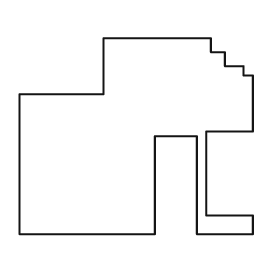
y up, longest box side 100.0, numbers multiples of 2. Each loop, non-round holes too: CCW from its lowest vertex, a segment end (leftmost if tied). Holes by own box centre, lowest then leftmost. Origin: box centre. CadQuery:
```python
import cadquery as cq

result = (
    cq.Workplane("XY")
    .moveTo(-50.0, -42.0)
    .lineTo(8.0, -42.0)
    .lineTo(8.0, 0.0)
    .lineTo(26.0, 0.0)
    .lineTo(26.0, -42.0)
    .lineTo(50.0, -42.0)
    .lineTo(50.0, -34.0)
    .lineTo(30.0, -34.0)
    .lineTo(30.0, 2.0)
    .lineTo(50.0, 2.0)
    .lineTo(50.0, 26.0)
    .lineTo(46.0, 26.0)
    .lineTo(46.0, 30.0)
    .lineTo(38.0, 30.0)
    .lineTo(38.0, 36.0)
    .lineTo(32.0, 36.0)
    .lineTo(32.0, 42.0)
    .lineTo(-14.0, 42.0)
    .lineTo(-14.0, 18.0)
    .lineTo(-50.0, 18.0)
    .close()
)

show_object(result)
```